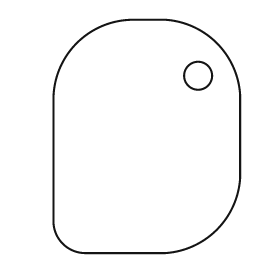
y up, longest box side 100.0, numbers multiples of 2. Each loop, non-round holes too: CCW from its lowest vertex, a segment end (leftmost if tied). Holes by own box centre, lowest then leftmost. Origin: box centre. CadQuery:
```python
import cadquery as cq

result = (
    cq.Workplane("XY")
    .moveTo(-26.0, -50.0)
    .lineTo(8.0, -50.0)
    .threePointArc((30.0, -40.0), (40.0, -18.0))
    .lineTo(40.0, 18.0)
    .threePointArc((30.0, 40.0), (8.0, 50.0))
    .lineTo(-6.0, 50.0)
    .threePointArc((-30.0, 40.0), (-40.0, 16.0))
    .lineTo(-40.0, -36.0)
    .threePointArc((-36.0, -46.0), (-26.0, -50.0))
    .close()
    .moveTo(22.0, 26.0)
    .circle(6.0)
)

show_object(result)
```